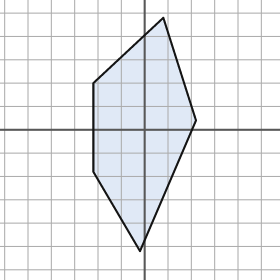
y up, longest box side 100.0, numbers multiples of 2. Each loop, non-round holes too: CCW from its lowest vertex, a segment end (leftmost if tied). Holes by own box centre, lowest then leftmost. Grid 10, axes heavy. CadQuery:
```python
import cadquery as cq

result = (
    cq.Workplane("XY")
    .moveTo(-2.0, -52.0)
    .lineTo(22.0, 4.0)
    .lineTo(8.0, 48.0)
    .lineTo(-22.0, 20.0)
    .lineTo(-22.0, -18.0)
    .close()
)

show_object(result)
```